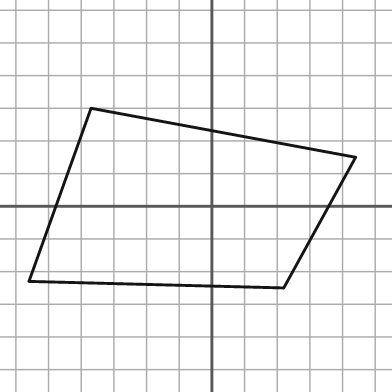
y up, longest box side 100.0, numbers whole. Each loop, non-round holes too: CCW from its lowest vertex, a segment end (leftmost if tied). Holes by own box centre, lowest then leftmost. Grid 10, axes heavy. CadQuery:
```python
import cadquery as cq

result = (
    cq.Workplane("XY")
    .moveTo(22.0, -25.0)
    .lineTo(44.0, 15.0)
    .lineTo(-37.0, 30.0)
    .lineTo(-56.0, -23.0)
    .close()
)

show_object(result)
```